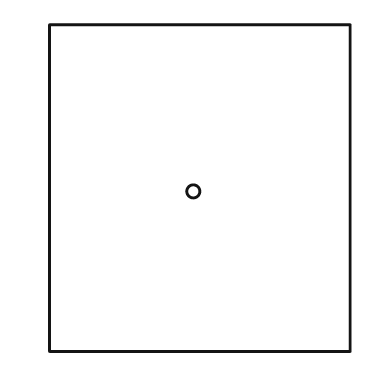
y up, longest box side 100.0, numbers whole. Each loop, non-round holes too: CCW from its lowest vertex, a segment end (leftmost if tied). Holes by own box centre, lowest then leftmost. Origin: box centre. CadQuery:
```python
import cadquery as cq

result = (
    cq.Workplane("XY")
    .moveTo(-46.0, -50.0)
    .lineTo(46.0, -50.0)
    .lineTo(46.0, 50.0)
    .lineTo(-46.0, 50.0)
    .close()
    .moveTo(-2.0, -1.0)
    .circle(2.0)
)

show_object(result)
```